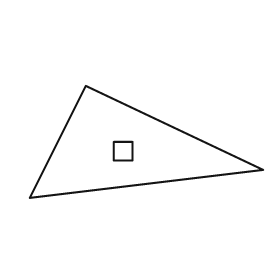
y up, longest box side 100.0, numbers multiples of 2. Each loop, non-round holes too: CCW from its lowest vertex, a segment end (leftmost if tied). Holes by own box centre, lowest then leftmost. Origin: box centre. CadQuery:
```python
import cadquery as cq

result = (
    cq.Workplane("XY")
    .moveTo(-50.0, -24.0)
    .lineTo(50.0, -12.0)
    .lineTo(-26.0, 24.0)
    .close()
    .moveTo(-14.0, -8.0)
    .lineTo(-6.0, -8.0)
    .lineTo(-6.0, 0.0)
    .lineTo(-14.0, 0.0)
    .close()
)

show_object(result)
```